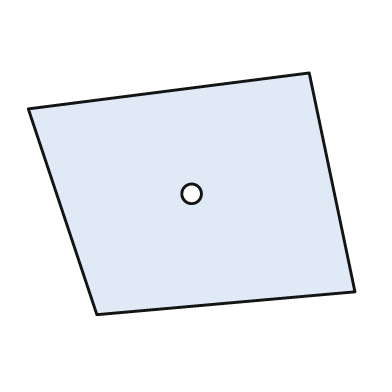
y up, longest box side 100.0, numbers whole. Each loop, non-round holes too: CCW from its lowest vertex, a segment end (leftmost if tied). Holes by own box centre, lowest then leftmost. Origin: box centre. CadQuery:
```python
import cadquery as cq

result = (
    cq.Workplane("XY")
    .moveTo(-29.0, -37.0)
    .lineTo(50.0, -30.0)
    .lineTo(36.0, 37.0)
    .lineTo(-50.0, 26.0)
    .close()
    .moveTo(0.0, 0.0)
    .circle(3.0)
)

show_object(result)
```